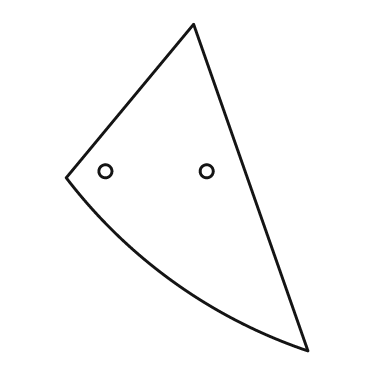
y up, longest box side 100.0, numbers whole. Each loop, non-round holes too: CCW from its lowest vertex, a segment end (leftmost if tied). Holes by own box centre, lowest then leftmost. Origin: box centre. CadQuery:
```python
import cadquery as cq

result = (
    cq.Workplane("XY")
    .moveTo(37.0, -50.0)
    .lineTo(2.0, 50.0)
    .lineTo(-37.0, 3.0)
    .threePointArc((-4.0, -29.0), (37.0, -50.0))
    .close()
    .moveTo(-25.0, 5.0)
    .circle(2.0)
    .moveTo(6.0, 5.0)
    .circle(2.0)
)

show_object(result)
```